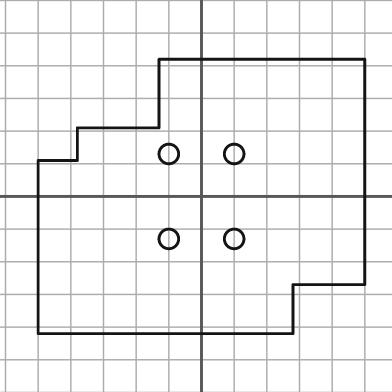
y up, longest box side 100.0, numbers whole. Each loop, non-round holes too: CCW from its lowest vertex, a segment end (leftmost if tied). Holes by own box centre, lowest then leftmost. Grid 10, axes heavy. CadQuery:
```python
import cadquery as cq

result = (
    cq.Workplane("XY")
    .moveTo(-50.0, -42.0)
    .lineTo(28.0, -42.0)
    .lineTo(28.0, -27.0)
    .lineTo(50.0, -27.0)
    .lineTo(50.0, 42.0)
    .lineTo(-13.0, 42.0)
    .lineTo(-13.0, 21.0)
    .lineTo(-38.0, 21.0)
    .lineTo(-38.0, 11.0)
    .lineTo(-50.0, 11.0)
    .close()
    .moveTo(-10.0, -13.0)
    .circle(3.0)
    .moveTo(10.0, -13.0)
    .circle(3.0)
    .moveTo(-10.0, 13.0)
    .circle(3.0)
    .moveTo(10.0, 13.0)
    .circle(3.0)
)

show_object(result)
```